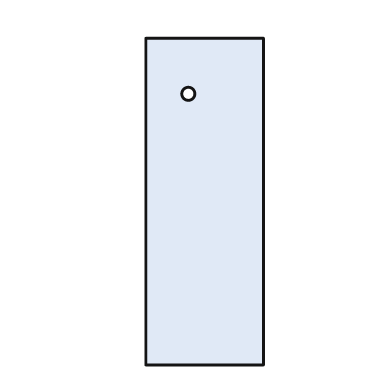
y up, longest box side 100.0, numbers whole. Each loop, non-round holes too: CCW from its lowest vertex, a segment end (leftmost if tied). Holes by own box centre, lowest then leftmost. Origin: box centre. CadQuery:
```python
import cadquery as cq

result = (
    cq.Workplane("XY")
    .moveTo(-18.0, -50.0)
    .lineTo(18.0, -50.0)
    .lineTo(18.0, 50.0)
    .lineTo(-18.0, 50.0)
    .close()
    .moveTo(-5.0, 33.0)
    .circle(2.0)
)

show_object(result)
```